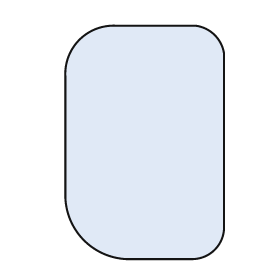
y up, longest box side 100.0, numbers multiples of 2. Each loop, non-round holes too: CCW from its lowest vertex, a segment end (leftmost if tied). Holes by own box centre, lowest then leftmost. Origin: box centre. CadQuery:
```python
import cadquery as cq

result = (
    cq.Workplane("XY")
    .moveTo(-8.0, -50.0)
    .lineTo(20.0, -50.0)
    .threePointArc((30.0, -46.0), (34.0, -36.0))
    .lineTo(34.0, 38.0)
    .threePointArc((30.0, 46.0), (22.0, 50.0))
    .lineTo(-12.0, 50.0)
    .threePointArc((-28.0, 44.0), (-34.0, 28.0))
    .lineTo(-34.0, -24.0)
    .threePointArc((-26.0, -42.0), (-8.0, -50.0))
    .close()
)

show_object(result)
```